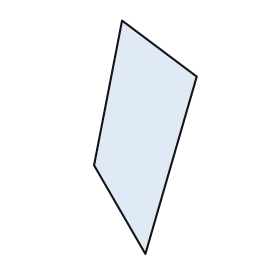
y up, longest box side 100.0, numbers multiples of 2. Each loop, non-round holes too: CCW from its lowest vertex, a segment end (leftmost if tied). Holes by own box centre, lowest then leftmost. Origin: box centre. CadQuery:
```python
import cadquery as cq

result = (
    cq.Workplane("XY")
    .moveTo(0.0, -50.0)
    .lineTo(22.0, 26.0)
    .lineTo(-10.0, 50.0)
    .lineTo(-22.0, -12.0)
    .close()
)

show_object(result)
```